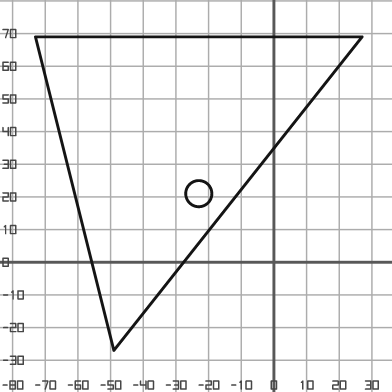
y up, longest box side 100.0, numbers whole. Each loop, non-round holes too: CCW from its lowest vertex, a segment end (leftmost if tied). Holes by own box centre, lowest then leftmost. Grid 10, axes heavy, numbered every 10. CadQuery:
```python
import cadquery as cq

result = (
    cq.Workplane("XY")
    .moveTo(-49.0, -27.0)
    .lineTo(27.0, 69.0)
    .lineTo(-73.0, 69.0)
    .close()
    .moveTo(-23.0, 21.0)
    .circle(4.0)
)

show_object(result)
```